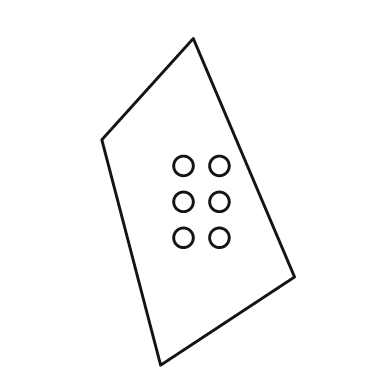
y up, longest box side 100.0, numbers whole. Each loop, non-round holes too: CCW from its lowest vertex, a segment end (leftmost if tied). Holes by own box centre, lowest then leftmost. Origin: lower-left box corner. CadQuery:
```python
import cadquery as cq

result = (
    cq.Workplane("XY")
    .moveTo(18.0, 0.0)
    .lineTo(59.0, 27.0)
    .lineTo(28.0, 100.0)
    .lineTo(0.0, 69.0)
    .close()
    .moveTo(25.0, 39.0)
    .circle(3.0)
    .moveTo(36.0, 39.0)
    .circle(3.0)
    .moveTo(25.0, 50.0)
    .circle(3.0)
    .moveTo(36.0, 50.0)
    .circle(3.0)
    .moveTo(25.0, 61.0)
    .circle(3.0)
    .moveTo(36.0, 61.0)
    .circle(3.0)
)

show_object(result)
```